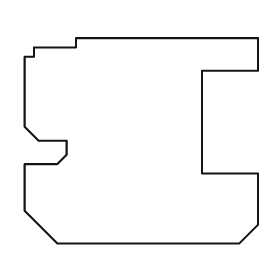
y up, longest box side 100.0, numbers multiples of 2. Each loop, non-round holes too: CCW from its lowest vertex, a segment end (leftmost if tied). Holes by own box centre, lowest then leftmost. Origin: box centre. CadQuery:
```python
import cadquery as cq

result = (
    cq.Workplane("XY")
    .moveTo(-36.0, -44.0)
    .lineTo(42.0, -44.0)
    .lineTo(50.0, -36.0)
    .lineTo(50.0, -14.0)
    .lineTo(26.0, -14.0)
    .lineTo(26.0, 30.0)
    .lineTo(50.0, 30.0)
    .lineTo(50.0, 44.0)
    .lineTo(-28.0, 44.0)
    .lineTo(-28.0, 40.0)
    .lineTo(-46.0, 40.0)
    .lineTo(-46.0, 36.0)
    .lineTo(-50.0, 36.0)
    .lineTo(-50.0, 6.0)
    .lineTo(-44.0, 0.0)
    .lineTo(-32.0, 0.0)
    .lineTo(-32.0, -6.0)
    .lineTo(-36.0, -10.0)
    .lineTo(-50.0, -10.0)
    .lineTo(-50.0, -30.0)
    .close()
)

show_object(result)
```